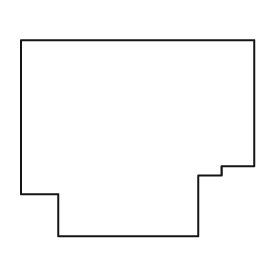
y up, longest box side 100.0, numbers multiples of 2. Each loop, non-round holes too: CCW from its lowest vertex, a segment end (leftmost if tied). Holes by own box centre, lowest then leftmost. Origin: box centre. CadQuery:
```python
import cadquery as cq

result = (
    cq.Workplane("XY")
    .moveTo(-34.0, -42.0)
    .lineTo(26.0, -42.0)
    .lineTo(26.0, -16.0)
    .lineTo(36.0, -16.0)
    .lineTo(36.0, -12.0)
    .lineTo(50.0, -12.0)
    .lineTo(50.0, 42.0)
    .lineTo(-50.0, 42.0)
    .lineTo(-50.0, -24.0)
    .lineTo(-34.0, -24.0)
    .close()
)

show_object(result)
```